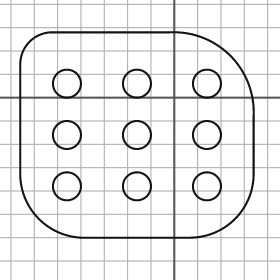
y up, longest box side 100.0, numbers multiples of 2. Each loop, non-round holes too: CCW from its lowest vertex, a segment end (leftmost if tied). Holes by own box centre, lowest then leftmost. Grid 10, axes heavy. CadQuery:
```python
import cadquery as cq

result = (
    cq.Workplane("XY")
    .moveTo(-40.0, -60.0)
    .lineTo(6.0, -60.0)
    .threePointArc((26.0, -52.0), (34.0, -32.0))
    .lineTo(34.0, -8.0)
    .threePointArc((24.0, 18.0), (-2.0, 28.0))
    .lineTo(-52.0, 28.0)
    .threePointArc((-62.0, 24.0), (-66.0, 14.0))
    .lineTo(-66.0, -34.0)
    .threePointArc((-58.0, -52.0), (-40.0, -60.0))
    .close()
    .moveTo(-46.0, -38.0)
    .circle(6.0)
    .moveTo(-16.0, -38.0)
    .circle(6.0)
    .moveTo(14.0, -38.0)
    .circle(6.0)
    .moveTo(-46.0, -16.0)
    .circle(6.0)
    .moveTo(-16.0, -16.0)
    .circle(6.0)
    .moveTo(14.0, -16.0)
    .circle(6.0)
    .moveTo(-46.0, 6.0)
    .circle(6.0)
    .moveTo(-16.0, 6.0)
    .circle(6.0)
    .moveTo(14.0, 6.0)
    .circle(6.0)
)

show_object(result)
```